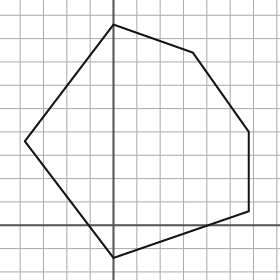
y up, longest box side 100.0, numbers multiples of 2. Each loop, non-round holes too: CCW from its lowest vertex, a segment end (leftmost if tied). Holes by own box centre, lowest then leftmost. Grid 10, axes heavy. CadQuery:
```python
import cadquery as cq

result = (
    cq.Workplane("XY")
    .moveTo(0.0, -14.0)
    .lineTo(58.0, 6.0)
    .lineTo(58.0, 40.0)
    .lineTo(34.0, 74.0)
    .lineTo(0.0, 86.0)
    .lineTo(-38.0, 36.0)
    .close()
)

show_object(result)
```